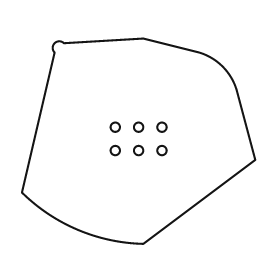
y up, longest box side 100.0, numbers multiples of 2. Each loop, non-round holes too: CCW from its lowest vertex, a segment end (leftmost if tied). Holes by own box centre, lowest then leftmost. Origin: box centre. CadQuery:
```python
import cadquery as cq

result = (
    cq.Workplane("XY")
    .moveTo(2.0, -44.0)
    .lineTo(50.0, -8.0)
    .lineTo(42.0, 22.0)
    .threePointArc((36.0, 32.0), (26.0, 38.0))
    .lineTo(2.0, 44.0)
    .lineTo(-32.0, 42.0)
    .threePointArc((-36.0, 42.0), (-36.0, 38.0))
    .lineTo(-50.0, -22.0)
    .threePointArc((-26.0, -38.0), (2.0, -44.0))
    .close()
    .moveTo(-10.0, -4.0)
    .circle(2.0)
    .moveTo(0.0, -4.0)
    .circle(2.0)
    .moveTo(10.0, -4.0)
    .circle(2.0)
    .moveTo(-10.0, 6.0)
    .circle(2.0)
    .moveTo(0.0, 6.0)
    .circle(2.0)
    .moveTo(10.0, 6.0)
    .circle(2.0)
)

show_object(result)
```